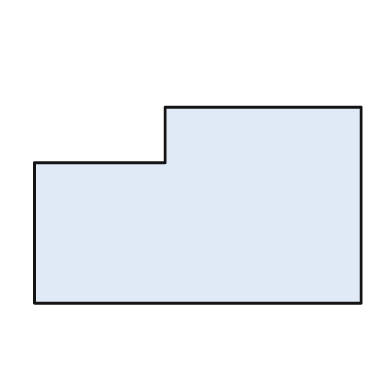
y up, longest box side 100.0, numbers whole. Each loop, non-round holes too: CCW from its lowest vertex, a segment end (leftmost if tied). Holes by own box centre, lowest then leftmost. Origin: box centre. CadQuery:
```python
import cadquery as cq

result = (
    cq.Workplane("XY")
    .moveTo(-50.0, -30.0)
    .lineTo(50.0, -30.0)
    .lineTo(50.0, 30.0)
    .lineTo(-10.0, 30.0)
    .lineTo(-10.0, 13.0)
    .lineTo(-50.0, 13.0)
    .close()
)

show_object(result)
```